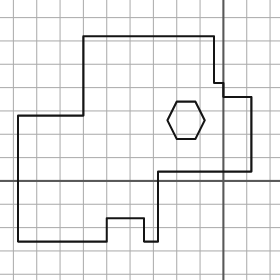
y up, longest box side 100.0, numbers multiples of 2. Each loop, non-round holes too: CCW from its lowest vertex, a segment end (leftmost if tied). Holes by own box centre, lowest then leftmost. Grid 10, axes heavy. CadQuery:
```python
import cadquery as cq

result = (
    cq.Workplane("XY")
    .moveTo(-88.0, -26.0)
    .lineTo(-50.0, -26.0)
    .lineTo(-50.0, -16.0)
    .lineTo(-34.0, -16.0)
    .lineTo(-34.0, -26.0)
    .lineTo(-28.0, -26.0)
    .lineTo(-28.0, 4.0)
    .lineTo(12.0, 4.0)
    .lineTo(12.0, 36.0)
    .lineTo(0.0, 36.0)
    .lineTo(0.0, 42.0)
    .lineTo(-4.0, 42.0)
    .lineTo(-4.0, 62.0)
    .lineTo(-60.0, 62.0)
    .lineTo(-60.0, 28.0)
    .lineTo(-88.0, 28.0)
    .close()
    .moveTo(-20.0, 18.0)
    .lineTo(-12.0, 18.0)
    .lineTo(-8.0, 26.0)
    .lineTo(-12.0, 34.0)
    .lineTo(-20.0, 34.0)
    .lineTo(-24.0, 26.0)
    .close()
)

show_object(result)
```